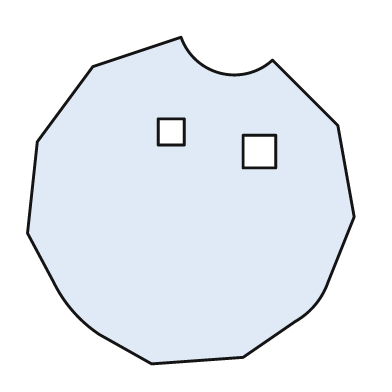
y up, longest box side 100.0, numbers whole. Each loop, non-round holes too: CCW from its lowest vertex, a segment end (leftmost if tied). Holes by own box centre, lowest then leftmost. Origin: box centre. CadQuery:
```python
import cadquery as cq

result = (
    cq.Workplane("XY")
    .moveTo(-12.0, -50.0)
    .lineTo(16.0, -48.0)
    .lineTo(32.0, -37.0)
    .threePointArc((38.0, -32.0), (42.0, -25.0))
    .lineTo(50.0, -5.0)
    .lineTo(45.0, 23.0)
    .lineTo(25.0, 43.0)
    .threePointArc((9.0, 39.0), (-3.0, 50.0))
    .lineTo(-30.0, 41.0)
    .lineTo(-47.0, 18.0)
    .lineTo(-50.0, -10.0)
    .lineTo(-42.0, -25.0)
    .threePointArc((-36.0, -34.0), (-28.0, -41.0))
    .close()
    .moveTo(16.0, 10.0)
    .lineTo(26.0, 10.0)
    .lineTo(26.0, 20.0)
    .lineTo(16.0, 20.0)
    .close()
    .moveTo(-10.0, 17.0)
    .lineTo(-2.0, 17.0)
    .lineTo(-2.0, 25.0)
    .lineTo(-10.0, 25.0)
    .close()
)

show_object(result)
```